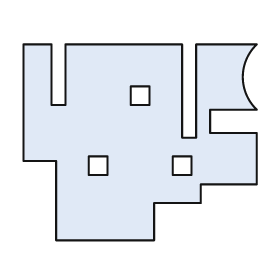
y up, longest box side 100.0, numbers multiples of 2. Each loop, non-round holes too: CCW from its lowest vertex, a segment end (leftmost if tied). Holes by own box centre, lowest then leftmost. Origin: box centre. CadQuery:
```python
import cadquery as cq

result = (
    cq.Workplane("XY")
    .moveTo(-36.0, -42.0)
    .lineTo(6.0, -42.0)
    .lineTo(6.0, -26.0)
    .lineTo(26.0, -26.0)
    .lineTo(26.0, -18.0)
    .lineTo(50.0, -18.0)
    .lineTo(50.0, 4.0)
    .lineTo(30.0, 4.0)
    .lineTo(30.0, 14.0)
    .lineTo(50.0, 14.0)
    .threePointArc((44.0, 28.0), (50.0, 42.0))
    .lineTo(24.0, 42.0)
    .lineTo(24.0, 2.0)
    .lineTo(18.0, 2.0)
    .lineTo(18.0, 42.0)
    .lineTo(-32.0, 42.0)
    .lineTo(-32.0, 16.0)
    .lineTo(-38.0, 16.0)
    .lineTo(-38.0, 42.0)
    .lineTo(-50.0, 42.0)
    .lineTo(-50.0, -8.0)
    .lineTo(-36.0, -8.0)
    .close()
    .moveTo(-22.0, -14.0)
    .lineTo(-14.0, -14.0)
    .lineTo(-14.0, -6.0)
    .lineTo(-22.0, -6.0)
    .close()
    .moveTo(14.0, -14.0)
    .lineTo(22.0, -14.0)
    .lineTo(22.0, -6.0)
    .lineTo(14.0, -6.0)
    .close()
    .moveTo(-4.0, 16.0)
    .lineTo(4.0, 16.0)
    .lineTo(4.0, 24.0)
    .lineTo(-4.0, 24.0)
    .close()
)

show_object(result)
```